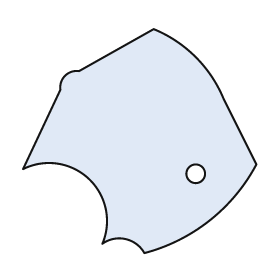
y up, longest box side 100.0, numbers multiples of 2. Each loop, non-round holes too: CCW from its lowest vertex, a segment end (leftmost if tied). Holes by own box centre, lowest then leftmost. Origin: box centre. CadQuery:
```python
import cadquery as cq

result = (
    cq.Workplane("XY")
    .moveTo(2.0, -48.0)
    .threePointArc((30.0, -34.0), (50.0, -10.0))
    .lineTo(36.0, 18.0)
    .threePointArc((24.0, 36.0), (6.0, 48.0))
    .lineTo(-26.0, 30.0)
    .threePointArc((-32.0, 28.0), (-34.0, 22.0))
    .lineTo(-50.0, -12.0)
    .threePointArc((-22.0, -16.0), (-16.0, -44.0))
    .threePointArc((-6.0, -42.0), (2.0, -48.0))
    .close()
    .moveTo(24.0, -14.0)
    .circle(4.0)
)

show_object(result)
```